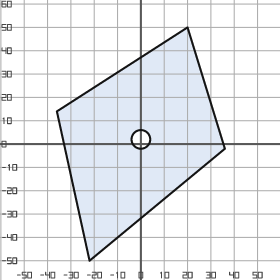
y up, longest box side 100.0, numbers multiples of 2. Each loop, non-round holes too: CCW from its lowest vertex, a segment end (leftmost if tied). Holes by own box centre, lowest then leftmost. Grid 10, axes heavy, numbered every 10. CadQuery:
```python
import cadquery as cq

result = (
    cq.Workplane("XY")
    .moveTo(-22.0, -50.0)
    .lineTo(36.0, -2.0)
    .lineTo(20.0, 50.0)
    .lineTo(-36.0, 14.0)
    .close()
    .moveTo(0.0, 2.0)
    .circle(4.0)
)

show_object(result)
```